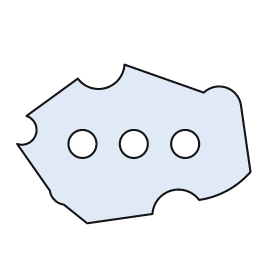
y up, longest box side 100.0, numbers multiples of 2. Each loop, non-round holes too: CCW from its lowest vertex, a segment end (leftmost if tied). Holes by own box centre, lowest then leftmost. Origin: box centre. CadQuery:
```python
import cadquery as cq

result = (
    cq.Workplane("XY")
    .moveTo(-20.0, -34.0)
    .lineTo(8.0, -30.0)
    .threePointArc((16.0, -20.0), (28.0, -24.0))
    .threePointArc((40.0, -20.0), (50.0, -12.0))
    .lineTo(46.0, 16.0)
    .threePointArc((40.0, 24.0), (30.0, 22.0))
    .lineTo(-4.0, 34.0)
    .threePointArc((-12.0, 24.0), (-24.0, 28.0))
    .lineTo(-46.0, 12.0)
    .threePointArc((-42.0, 4.0), (-50.0, 0.0))
    .lineTo(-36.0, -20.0)
    .threePointArc((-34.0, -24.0), (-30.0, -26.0))
    .close()
    .moveTo(-22.0, 0.0)
    .circle(6.0)
    .moveTo(0.0, 0.0)
    .circle(6.0)
    .moveTo(22.0, 0.0)
    .circle(6.0)
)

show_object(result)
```